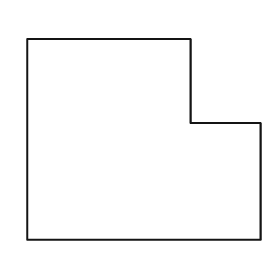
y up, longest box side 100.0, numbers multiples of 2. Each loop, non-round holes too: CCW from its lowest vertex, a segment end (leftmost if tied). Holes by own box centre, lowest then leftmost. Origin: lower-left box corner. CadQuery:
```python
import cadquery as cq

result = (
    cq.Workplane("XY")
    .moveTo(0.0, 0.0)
    .lineTo(100.0, 0.0)
    .lineTo(100.0, 50.0)
    .lineTo(70.0, 50.0)
    .lineTo(70.0, 86.0)
    .lineTo(0.0, 86.0)
    .close()
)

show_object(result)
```